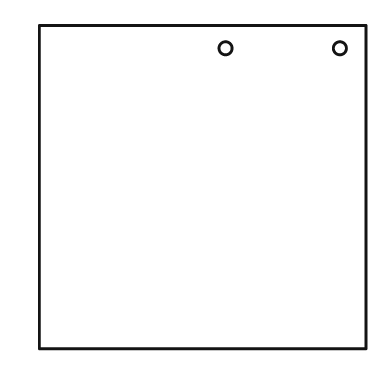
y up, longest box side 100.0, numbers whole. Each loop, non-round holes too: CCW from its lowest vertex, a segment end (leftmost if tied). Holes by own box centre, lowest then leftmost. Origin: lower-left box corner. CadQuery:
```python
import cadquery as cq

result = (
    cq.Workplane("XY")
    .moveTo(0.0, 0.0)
    .lineTo(100.0, 0.0)
    .lineTo(100.0, 99.0)
    .lineTo(0.0, 99.0)
    .close()
    .moveTo(57.0, 92.0)
    .circle(2.0)
    .moveTo(92.0, 92.0)
    .circle(2.0)
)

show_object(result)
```